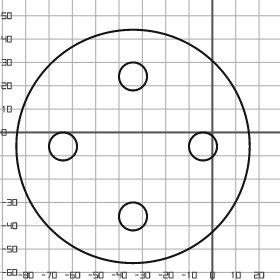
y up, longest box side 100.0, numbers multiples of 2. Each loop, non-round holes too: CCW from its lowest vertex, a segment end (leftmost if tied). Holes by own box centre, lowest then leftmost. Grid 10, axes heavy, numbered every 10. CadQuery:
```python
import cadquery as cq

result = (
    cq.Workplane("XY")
    .moveTo(-34.0, -6.0)
    .circle(50.0)
    .moveTo(-34.0, -36.0)
    .circle(6.0)
    .moveTo(-64.0, -6.0)
    .circle(6.0)
    .moveTo(-4.0, -6.0)
    .circle(6.0)
    .moveTo(-34.0, 24.0)
    .circle(6.0)
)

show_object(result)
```